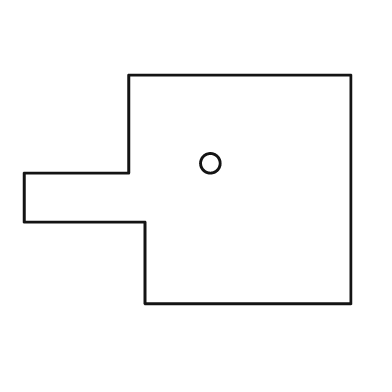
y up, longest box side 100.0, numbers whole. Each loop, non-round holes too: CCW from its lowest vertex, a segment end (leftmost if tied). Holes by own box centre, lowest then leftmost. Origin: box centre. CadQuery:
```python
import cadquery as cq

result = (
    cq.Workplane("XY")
    .moveTo(-13.0, -35.0)
    .lineTo(50.0, -35.0)
    .lineTo(50.0, 35.0)
    .lineTo(-18.0, 35.0)
    .lineTo(-18.0, 5.0)
    .lineTo(-50.0, 5.0)
    .lineTo(-50.0, -10.0)
    .lineTo(-13.0, -10.0)
    .close()
    .moveTo(7.0, 8.0)
    .circle(3.0)
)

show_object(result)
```